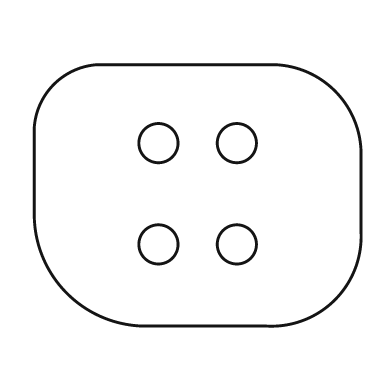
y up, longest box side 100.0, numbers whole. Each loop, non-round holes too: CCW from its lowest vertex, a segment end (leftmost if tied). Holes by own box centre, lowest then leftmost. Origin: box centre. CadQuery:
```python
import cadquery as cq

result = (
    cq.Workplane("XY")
    .moveTo(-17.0, -40.0)
    .lineTo(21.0, -40.0)
    .threePointArc((42.0, -32.0), (50.0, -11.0))
    .lineTo(50.0, 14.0)
    .threePointArc((42.0, 32.0), (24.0, 40.0))
    .lineTo(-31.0, 40.0)
    .threePointArc((-44.0, 34.0), (-50.0, 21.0))
    .lineTo(-50.0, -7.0)
    .threePointArc((-40.0, -30.0), (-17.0, -40.0))
    .close()
    .moveTo(-12.0, -15.0)
    .circle(6.0)
    .moveTo(12.0, -15.0)
    .circle(6.0)
    .moveTo(-12.0, 16.0)
    .circle(6.0)
    .moveTo(12.0, 16.0)
    .circle(6.0)
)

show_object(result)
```